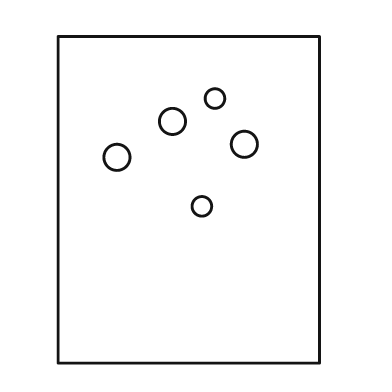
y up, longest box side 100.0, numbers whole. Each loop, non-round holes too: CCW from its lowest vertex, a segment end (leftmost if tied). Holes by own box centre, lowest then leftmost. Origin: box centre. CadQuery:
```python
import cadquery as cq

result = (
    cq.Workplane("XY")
    .moveTo(-40.0, -50.0)
    .lineTo(40.0, -50.0)
    .lineTo(40.0, 50.0)
    .lineTo(-40.0, 50.0)
    .close()
    .moveTo(4.0, -2.0)
    .circle(3.0)
    .moveTo(-22.0, 13.0)
    .circle(4.0)
    .moveTo(17.0, 17.0)
    .circle(4.0)
    .moveTo(-5.0, 24.0)
    .circle(4.0)
    .moveTo(8.0, 31.0)
    .circle(3.0)
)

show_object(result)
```